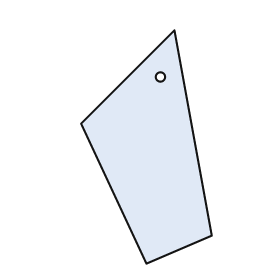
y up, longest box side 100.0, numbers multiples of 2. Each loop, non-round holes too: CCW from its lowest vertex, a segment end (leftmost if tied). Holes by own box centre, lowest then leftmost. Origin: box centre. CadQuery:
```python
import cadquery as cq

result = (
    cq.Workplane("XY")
    .moveTo(0.0, -50.0)
    .lineTo(28.0, -38.0)
    .lineTo(12.0, 50.0)
    .lineTo(-28.0, 10.0)
    .close()
    .moveTo(6.0, 30.0)
    .circle(2.0)
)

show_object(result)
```